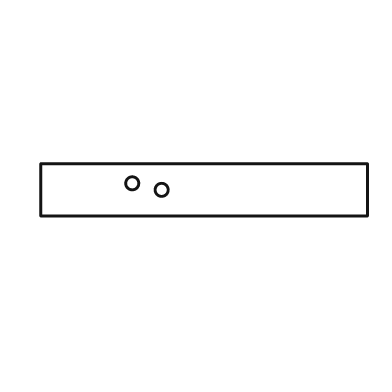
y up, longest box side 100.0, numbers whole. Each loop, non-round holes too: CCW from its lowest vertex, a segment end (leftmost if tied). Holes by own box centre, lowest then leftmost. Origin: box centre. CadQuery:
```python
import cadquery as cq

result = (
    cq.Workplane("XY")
    .moveTo(-50.0, -8.0)
    .lineTo(50.0, -8.0)
    .lineTo(50.0, 8.0)
    .lineTo(-50.0, 8.0)
    .close()
    .moveTo(-13.0, 0.0)
    .circle(2.0)
    .moveTo(-22.0, 2.0)
    .circle(2.0)
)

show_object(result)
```